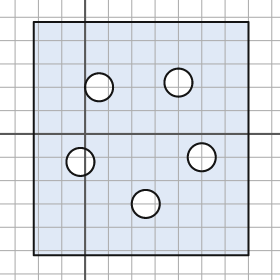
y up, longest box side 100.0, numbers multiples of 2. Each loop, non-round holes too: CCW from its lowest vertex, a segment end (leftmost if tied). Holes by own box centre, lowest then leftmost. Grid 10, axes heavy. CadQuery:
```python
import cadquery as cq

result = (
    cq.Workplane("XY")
    .moveTo(-22.0, -52.0)
    .lineTo(70.0, -52.0)
    .lineTo(70.0, 48.0)
    .lineTo(-22.0, 48.0)
    .close()
    .moveTo(26.0, -30.0)
    .circle(6.0)
    .moveTo(-2.0, -12.0)
    .circle(6.0)
    .moveTo(50.0, -10.0)
    .circle(6.0)
    .moveTo(6.0, 20.0)
    .circle(6.0)
    .moveTo(40.0, 22.0)
    .circle(6.0)
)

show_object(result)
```